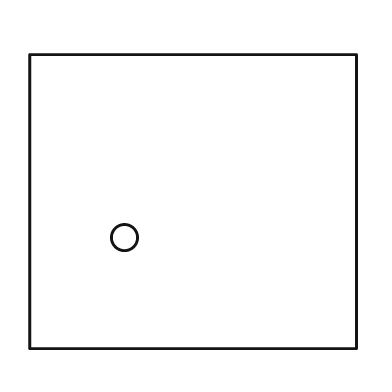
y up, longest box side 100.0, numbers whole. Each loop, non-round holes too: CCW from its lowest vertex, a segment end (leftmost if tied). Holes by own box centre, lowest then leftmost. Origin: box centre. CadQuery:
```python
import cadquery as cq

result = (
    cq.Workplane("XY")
    .moveTo(-50.0, -45.0)
    .lineTo(50.0, -45.0)
    .lineTo(50.0, 45.0)
    .lineTo(-50.0, 45.0)
    .close()
    .moveTo(-21.0, -11.0)
    .circle(4.0)
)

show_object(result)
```